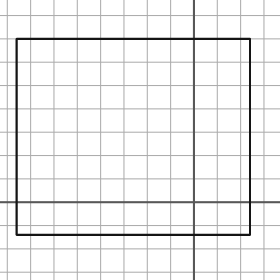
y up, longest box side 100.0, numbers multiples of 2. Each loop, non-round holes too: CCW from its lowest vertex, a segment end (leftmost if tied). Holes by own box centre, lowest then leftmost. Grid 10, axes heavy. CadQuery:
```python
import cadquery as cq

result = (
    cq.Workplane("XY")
    .moveTo(-76.0, -14.0)
    .lineTo(24.0, -14.0)
    .lineTo(24.0, 70.0)
    .lineTo(-76.0, 70.0)
    .close()
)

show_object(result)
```